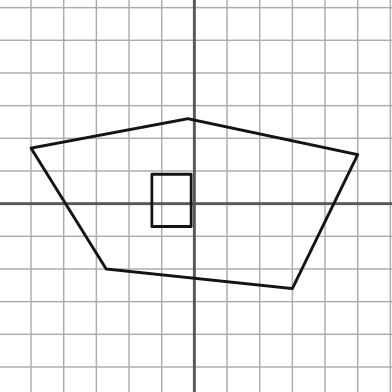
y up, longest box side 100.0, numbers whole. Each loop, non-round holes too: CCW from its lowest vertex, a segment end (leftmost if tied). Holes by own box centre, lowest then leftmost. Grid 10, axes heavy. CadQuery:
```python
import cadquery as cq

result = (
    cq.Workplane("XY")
    .moveTo(30.0, -26.0)
    .lineTo(50.0, 15.0)
    .lineTo(-2.0, 26.0)
    .lineTo(-50.0, 17.0)
    .lineTo(-27.0, -20.0)
    .close()
    .moveTo(-13.0, -7.0)
    .lineTo(-1.0, -7.0)
    .lineTo(-1.0, 9.0)
    .lineTo(-13.0, 9.0)
    .close()
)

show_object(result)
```